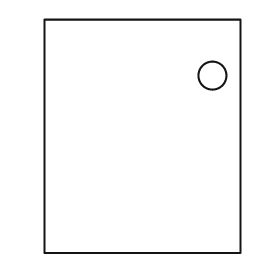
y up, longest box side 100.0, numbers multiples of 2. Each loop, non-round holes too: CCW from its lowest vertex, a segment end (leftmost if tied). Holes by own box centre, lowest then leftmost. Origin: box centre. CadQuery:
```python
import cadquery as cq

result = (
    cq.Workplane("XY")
    .moveTo(-42.0, -50.0)
    .lineTo(42.0, -50.0)
    .lineTo(42.0, 50.0)
    .lineTo(-42.0, 50.0)
    .close()
    .moveTo(30.0, 26.0)
    .circle(6.0)
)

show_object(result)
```